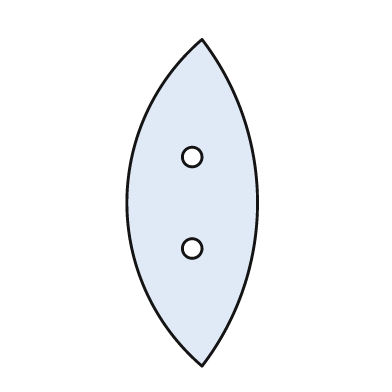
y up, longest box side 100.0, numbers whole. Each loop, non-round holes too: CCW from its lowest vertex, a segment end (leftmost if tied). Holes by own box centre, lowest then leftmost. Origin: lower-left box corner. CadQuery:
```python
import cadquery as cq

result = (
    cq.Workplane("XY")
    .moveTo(23.0, 0.0)
    .threePointArc((40.0, 50.0), (23.0, 100.0))
    .threePointArc((0.0, 50.0), (23.0, 0.0))
    .close()
    .moveTo(20.0, 36.0)
    .circle(3.0)
    .moveTo(20.0, 64.0)
    .circle(3.0)
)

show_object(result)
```